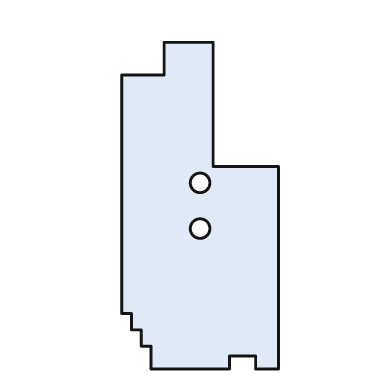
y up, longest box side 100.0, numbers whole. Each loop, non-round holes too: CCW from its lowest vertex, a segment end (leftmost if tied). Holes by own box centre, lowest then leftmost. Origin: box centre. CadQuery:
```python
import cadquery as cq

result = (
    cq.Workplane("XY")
    .moveTo(-15.0, -50.0)
    .lineTo(9.0, -50.0)
    .lineTo(9.0, -46.0)
    .lineTo(17.0, -46.0)
    .lineTo(17.0, -50.0)
    .lineTo(24.0, -50.0)
    .lineTo(24.0, 12.0)
    .lineTo(4.0, 12.0)
    .lineTo(4.0, 50.0)
    .lineTo(-11.0, 50.0)
    .lineTo(-11.0, 40.0)
    .lineTo(-24.0, 40.0)
    .lineTo(-24.0, -33.0)
    .lineTo(-21.0, -33.0)
    .lineTo(-21.0, -38.0)
    .lineTo(-18.0, -38.0)
    .lineTo(-18.0, -43.0)
    .lineTo(-15.0, -43.0)
    .close()
    .moveTo(0.0, -7.0)
    .circle(3.0)
    .moveTo(0.0, 7.0)
    .circle(3.0)
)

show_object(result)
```